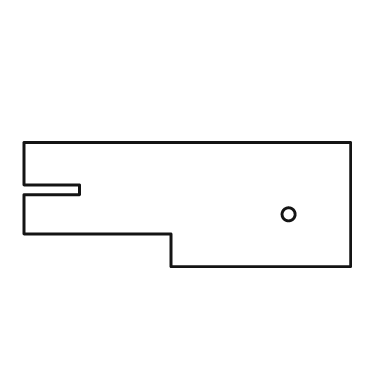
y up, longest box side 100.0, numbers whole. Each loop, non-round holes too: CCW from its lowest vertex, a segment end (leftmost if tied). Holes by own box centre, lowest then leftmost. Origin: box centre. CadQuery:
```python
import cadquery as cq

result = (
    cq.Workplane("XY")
    .moveTo(-5.0, -19.0)
    .lineTo(50.0, -19.0)
    .lineTo(50.0, 19.0)
    .lineTo(-50.0, 19.0)
    .lineTo(-50.0, 6.0)
    .lineTo(-33.0, 6.0)
    .lineTo(-33.0, 3.0)
    .lineTo(-50.0, 3.0)
    .lineTo(-50.0, -9.0)
    .lineTo(-5.0, -9.0)
    .close()
    .moveTo(31.0, -3.0)
    .circle(2.0)
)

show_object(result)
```